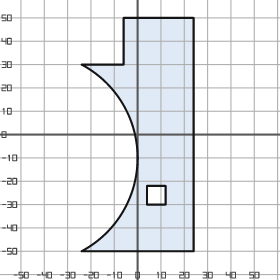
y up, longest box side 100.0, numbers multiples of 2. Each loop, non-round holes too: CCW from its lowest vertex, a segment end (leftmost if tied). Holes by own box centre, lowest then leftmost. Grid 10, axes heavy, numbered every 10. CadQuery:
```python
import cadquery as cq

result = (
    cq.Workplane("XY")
    .moveTo(-24.0, -50.0)
    .lineTo(24.0, -50.0)
    .lineTo(24.0, 50.0)
    .lineTo(-6.0, 50.0)
    .lineTo(-6.0, 30.0)
    .lineTo(-24.0, 30.0)
    .threePointArc((0.0, -10.0), (-24.0, -50.0))
    .close()
    .moveTo(4.0, -30.0)
    .lineTo(12.0, -30.0)
    .lineTo(12.0, -22.0)
    .lineTo(4.0, -22.0)
    .close()
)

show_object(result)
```